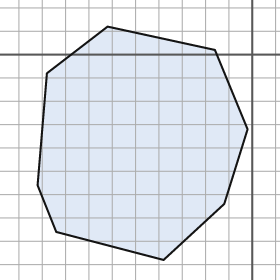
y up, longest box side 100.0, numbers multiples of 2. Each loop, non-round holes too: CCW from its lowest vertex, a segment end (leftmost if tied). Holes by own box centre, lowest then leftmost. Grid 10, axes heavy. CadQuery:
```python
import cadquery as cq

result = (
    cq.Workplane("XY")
    .moveTo(-38.0, -88.0)
    .lineTo(-12.0, -64.0)
    .lineTo(-2.0, -32.0)
    .lineTo(-16.0, 2.0)
    .lineTo(-62.0, 12.0)
    .lineTo(-88.0, -8.0)
    .lineTo(-92.0, -56.0)
    .lineTo(-84.0, -76.0)
    .close()
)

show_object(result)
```